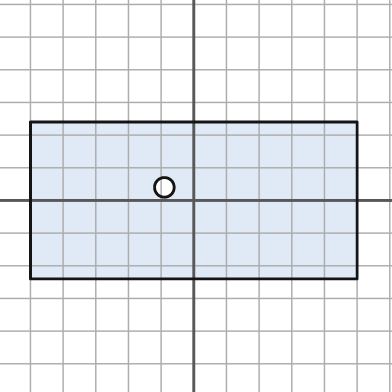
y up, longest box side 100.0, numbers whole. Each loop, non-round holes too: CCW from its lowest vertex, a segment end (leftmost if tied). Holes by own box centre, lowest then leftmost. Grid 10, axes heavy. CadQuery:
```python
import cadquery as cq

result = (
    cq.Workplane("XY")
    .moveTo(-50.0, -24.0)
    .lineTo(50.0, -24.0)
    .lineTo(50.0, 24.0)
    .lineTo(-50.0, 24.0)
    .close()
    .moveTo(-9.0, 4.0)
    .circle(3.0)
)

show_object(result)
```